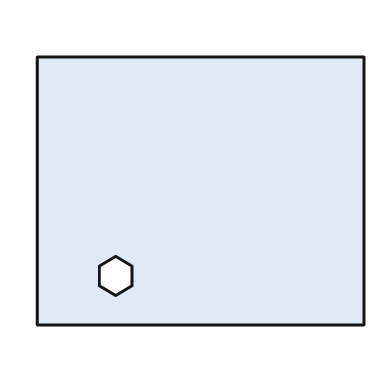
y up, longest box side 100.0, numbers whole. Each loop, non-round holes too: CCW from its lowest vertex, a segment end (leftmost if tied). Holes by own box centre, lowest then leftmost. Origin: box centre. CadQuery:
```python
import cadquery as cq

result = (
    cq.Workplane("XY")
    .moveTo(-50.0, -41.0)
    .lineTo(50.0, -41.0)
    .lineTo(50.0, 41.0)
    .lineTo(-50.0, 41.0)
    .close()
    .moveTo(-26.0, -32.0)
    .lineTo(-21.0, -29.0)
    .lineTo(-21.0, -23.0)
    .lineTo(-26.0, -20.0)
    .lineTo(-31.0, -23.0)
    .lineTo(-31.0, -29.0)
    .close()
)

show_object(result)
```